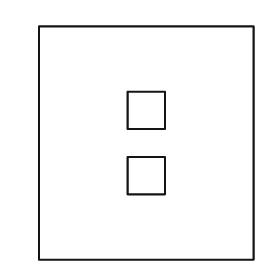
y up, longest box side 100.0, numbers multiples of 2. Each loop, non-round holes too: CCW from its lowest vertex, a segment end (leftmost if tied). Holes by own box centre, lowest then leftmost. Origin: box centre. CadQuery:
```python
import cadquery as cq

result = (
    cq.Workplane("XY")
    .moveTo(-46.0, -50.0)
    .lineTo(46.0, -50.0)
    .lineTo(46.0, 50.0)
    .lineTo(-46.0, 50.0)
    .close()
    .moveTo(-8.0, -22.0)
    .lineTo(8.0, -22.0)
    .lineTo(8.0, -6.0)
    .lineTo(-8.0, -6.0)
    .close()
    .moveTo(-8.0, 6.0)
    .lineTo(8.0, 6.0)
    .lineTo(8.0, 22.0)
    .lineTo(-8.0, 22.0)
    .close()
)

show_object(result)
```